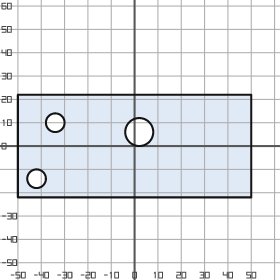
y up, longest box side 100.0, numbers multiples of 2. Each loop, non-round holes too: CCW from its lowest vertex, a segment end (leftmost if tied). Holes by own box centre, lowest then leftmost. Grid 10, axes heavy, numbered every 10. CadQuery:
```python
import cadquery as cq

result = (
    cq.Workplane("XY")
    .moveTo(-50.0, -22.0)
    .lineTo(50.0, -22.0)
    .lineTo(50.0, 22.0)
    .lineTo(-50.0, 22.0)
    .close()
    .moveTo(-42.0, -14.0)
    .circle(4.0)
    .moveTo(2.0, 6.0)
    .circle(6.0)
    .moveTo(-34.0, 10.0)
    .circle(4.0)
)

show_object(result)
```